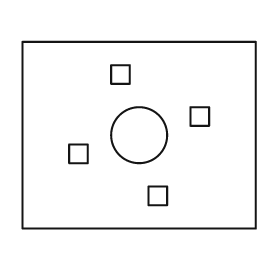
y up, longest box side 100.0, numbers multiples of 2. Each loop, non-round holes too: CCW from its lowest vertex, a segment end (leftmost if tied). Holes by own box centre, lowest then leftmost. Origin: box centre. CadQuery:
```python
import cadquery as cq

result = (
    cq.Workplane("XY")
    .moveTo(-50.0, -40.0)
    .lineTo(50.0, -40.0)
    .lineTo(50.0, 40.0)
    .lineTo(-50.0, 40.0)
    .close()
    .moveTo(4.0, -30.0)
    .lineTo(12.0, -30.0)
    .lineTo(12.0, -22.0)
    .lineTo(4.0, -22.0)
    .close()
    .moveTo(-30.0, -12.0)
    .lineTo(-22.0, -12.0)
    .lineTo(-22.0, -4.0)
    .lineTo(-30.0, -4.0)
    .close()
    .moveTo(0.0, 0.0)
    .circle(12.0)
    .moveTo(22.0, 4.0)
    .lineTo(30.0, 4.0)
    .lineTo(30.0, 12.0)
    .lineTo(22.0, 12.0)
    .close()
    .moveTo(-12.0, 22.0)
    .lineTo(-4.0, 22.0)
    .lineTo(-4.0, 30.0)
    .lineTo(-12.0, 30.0)
    .close()
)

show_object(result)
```